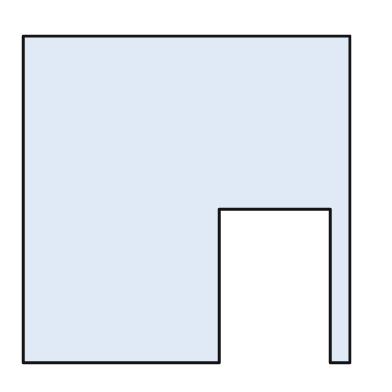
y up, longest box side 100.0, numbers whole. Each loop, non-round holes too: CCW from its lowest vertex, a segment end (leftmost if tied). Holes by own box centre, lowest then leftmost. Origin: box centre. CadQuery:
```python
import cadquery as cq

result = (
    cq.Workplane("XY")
    .moveTo(-50.0, -50.0)
    .lineTo(10.0, -50.0)
    .lineTo(10.0, -3.0)
    .lineTo(44.0, -3.0)
    .lineTo(44.0, -50.0)
    .lineTo(50.0, -50.0)
    .lineTo(50.0, 50.0)
    .lineTo(-50.0, 50.0)
    .close()
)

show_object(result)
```